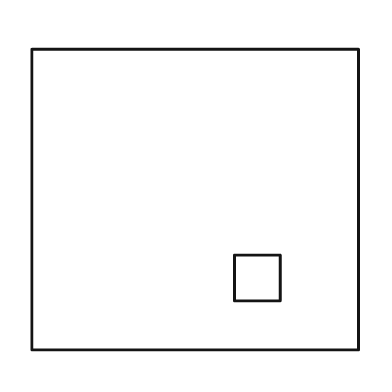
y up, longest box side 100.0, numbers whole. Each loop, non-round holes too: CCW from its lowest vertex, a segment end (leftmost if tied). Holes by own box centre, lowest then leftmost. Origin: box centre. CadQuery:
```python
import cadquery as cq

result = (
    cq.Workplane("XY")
    .moveTo(-50.0, -46.0)
    .lineTo(50.0, -46.0)
    .lineTo(50.0, 46.0)
    .lineTo(-50.0, 46.0)
    .close()
    .moveTo(12.0, -31.0)
    .lineTo(26.0, -31.0)
    .lineTo(26.0, -17.0)
    .lineTo(12.0, -17.0)
    .close()
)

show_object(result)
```